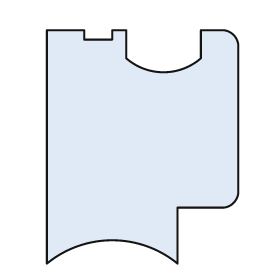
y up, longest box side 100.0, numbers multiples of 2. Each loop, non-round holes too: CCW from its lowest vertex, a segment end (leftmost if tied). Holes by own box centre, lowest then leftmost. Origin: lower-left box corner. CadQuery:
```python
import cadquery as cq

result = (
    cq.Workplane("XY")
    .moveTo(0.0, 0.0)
    .threePointArc((28.0, 10.0), (56.0, 0.0))
    .lineTo(56.0, 24.0)
    .lineTo(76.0, 24.0)
    .threePointArc((80.0, 26.0), (82.0, 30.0))
    .lineTo(82.0, 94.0)
    .threePointArc((80.0, 98.0), (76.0, 100.0))
    .lineTo(66.0, 100.0)
    .lineTo(66.0, 88.0)
    .threePointArc((50.0, 82.0), (34.0, 88.0))
    .lineTo(34.0, 100.0)
    .lineTo(28.0, 100.0)
    .lineTo(28.0, 96.0)
    .lineTo(16.0, 96.0)
    .lineTo(16.0, 100.0)
    .lineTo(0.0, 100.0)
    .close()
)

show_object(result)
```